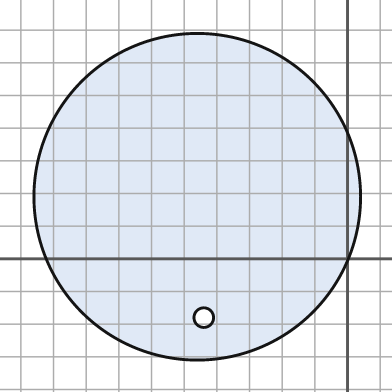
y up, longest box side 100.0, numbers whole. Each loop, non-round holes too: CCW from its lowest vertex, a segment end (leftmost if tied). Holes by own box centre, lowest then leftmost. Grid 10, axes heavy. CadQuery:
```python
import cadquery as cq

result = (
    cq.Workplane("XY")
    .moveTo(-46.0, 19.0)
    .circle(50.0)
    .moveTo(-44.0, -18.0)
    .circle(3.0)
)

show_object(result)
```